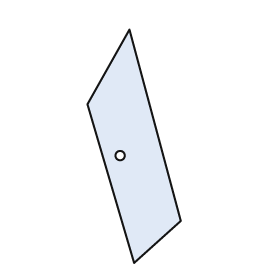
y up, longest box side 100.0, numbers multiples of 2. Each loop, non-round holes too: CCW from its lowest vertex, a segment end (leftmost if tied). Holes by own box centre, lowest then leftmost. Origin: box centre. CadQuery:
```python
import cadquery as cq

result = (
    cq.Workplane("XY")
    .moveTo(0.0, -50.0)
    .lineTo(20.0, -32.0)
    .lineTo(-2.0, 50.0)
    .lineTo(-20.0, 18.0)
    .close()
    .moveTo(-6.0, -4.0)
    .circle(2.0)
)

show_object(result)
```